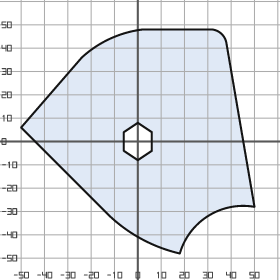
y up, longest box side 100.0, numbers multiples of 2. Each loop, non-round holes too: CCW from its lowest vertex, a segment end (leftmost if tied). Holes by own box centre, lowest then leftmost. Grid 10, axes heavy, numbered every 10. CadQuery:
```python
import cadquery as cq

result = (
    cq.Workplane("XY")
    .moveTo(18.0, -48.0)
    .threePointArc((30.0, -32.0), (50.0, -28.0))
    .lineTo(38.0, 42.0)
    .threePointArc((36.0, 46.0), (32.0, 48.0))
    .lineTo(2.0, 48.0)
    .threePointArc((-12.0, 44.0), (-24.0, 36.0))
    .lineTo(-50.0, 6.0)
    .lineTo(-12.0, -32.0)
    .threePointArc((2.0, -42.0), (18.0, -48.0))
    .close()
    .moveTo(0.0, -8.0)
    .lineTo(6.0, -4.0)
    .lineTo(6.0, 4.0)
    .lineTo(0.0, 8.0)
    .lineTo(-6.0, 4.0)
    .lineTo(-6.0, -4.0)
    .close()
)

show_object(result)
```